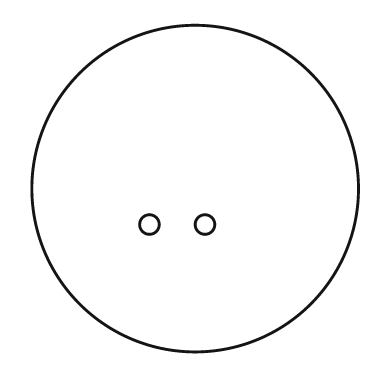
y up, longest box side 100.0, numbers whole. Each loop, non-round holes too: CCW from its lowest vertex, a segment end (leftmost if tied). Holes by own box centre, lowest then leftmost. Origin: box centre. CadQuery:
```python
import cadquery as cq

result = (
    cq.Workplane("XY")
    .moveTo(0.0, 0.0)
    .circle(50.0)
    .moveTo(-14.0, -11.0)
    .circle(3.0)
    .moveTo(3.0, -11.0)
    .circle(3.0)
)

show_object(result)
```